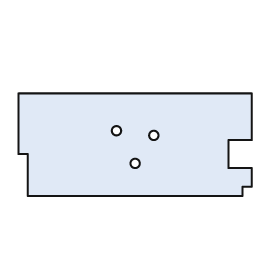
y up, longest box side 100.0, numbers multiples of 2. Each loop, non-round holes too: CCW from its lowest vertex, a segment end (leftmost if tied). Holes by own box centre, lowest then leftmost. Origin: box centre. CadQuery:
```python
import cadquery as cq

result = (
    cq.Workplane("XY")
    .moveTo(-46.0, -22.0)
    .lineTo(46.0, -22.0)
    .lineTo(46.0, -18.0)
    .lineTo(50.0, -18.0)
    .lineTo(50.0, -10.0)
    .lineTo(40.0, -10.0)
    .lineTo(40.0, 2.0)
    .lineTo(50.0, 2.0)
    .lineTo(50.0, 22.0)
    .lineTo(-50.0, 22.0)
    .lineTo(-50.0, -4.0)
    .lineTo(-46.0, -4.0)
    .close()
    .moveTo(0.0, -8.0)
    .circle(2.0)
    .moveTo(8.0, 4.0)
    .circle(2.0)
    .moveTo(-8.0, 6.0)
    .circle(2.0)
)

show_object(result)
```